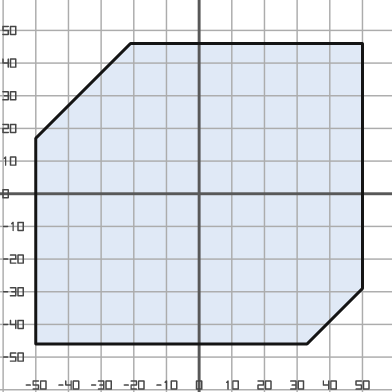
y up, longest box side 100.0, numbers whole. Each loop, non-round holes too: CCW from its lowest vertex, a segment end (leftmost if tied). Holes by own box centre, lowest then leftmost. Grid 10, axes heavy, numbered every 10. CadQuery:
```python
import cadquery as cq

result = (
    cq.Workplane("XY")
    .moveTo(-50.0, -46.0)
    .lineTo(33.0, -46.0)
    .lineTo(50.0, -29.0)
    .lineTo(50.0, 46.0)
    .lineTo(-21.0, 46.0)
    .lineTo(-50.0, 17.0)
    .close()
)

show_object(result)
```